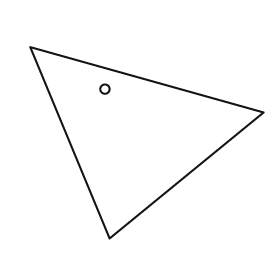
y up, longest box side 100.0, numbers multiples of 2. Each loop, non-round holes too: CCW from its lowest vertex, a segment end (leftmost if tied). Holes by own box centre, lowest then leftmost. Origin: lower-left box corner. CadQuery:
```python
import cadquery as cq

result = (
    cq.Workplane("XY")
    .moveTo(34.0, 0.0)
    .lineTo(100.0, 54.0)
    .lineTo(0.0, 82.0)
    .close()
    .moveTo(32.0, 64.0)
    .circle(2.0)
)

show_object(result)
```